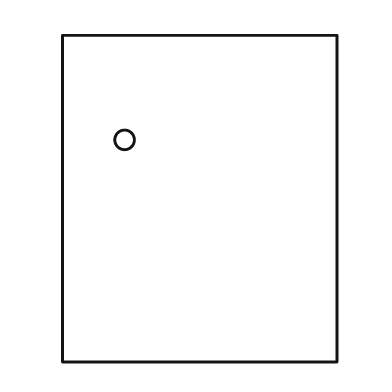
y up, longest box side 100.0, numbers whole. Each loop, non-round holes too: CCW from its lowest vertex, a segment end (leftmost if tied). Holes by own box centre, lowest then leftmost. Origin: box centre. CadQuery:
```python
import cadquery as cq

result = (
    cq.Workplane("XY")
    .moveTo(-42.0, -50.0)
    .lineTo(42.0, -50.0)
    .lineTo(42.0, 50.0)
    .lineTo(-42.0, 50.0)
    .close()
    .moveTo(-23.0, 18.0)
    .circle(3.0)
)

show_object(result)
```